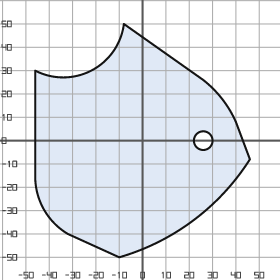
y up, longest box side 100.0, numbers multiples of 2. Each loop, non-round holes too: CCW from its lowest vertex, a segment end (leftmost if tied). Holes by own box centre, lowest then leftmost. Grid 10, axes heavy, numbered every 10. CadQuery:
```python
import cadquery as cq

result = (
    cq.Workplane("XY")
    .moveTo(-10.0, -50.0)
    .threePointArc((22.0, -34.0), (46.0, -8.0))
    .lineTo(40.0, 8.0)
    .threePointArc((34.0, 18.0), (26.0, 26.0))
    .lineTo(-8.0, 50.0)
    .threePointArc((-22.0, 30.0), (-46.0, 30.0))
    .lineTo(-46.0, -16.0)
    .threePointArc((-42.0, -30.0), (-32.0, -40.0))
    .close()
    .moveTo(26.0, 0.0)
    .circle(4.0)
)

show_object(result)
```